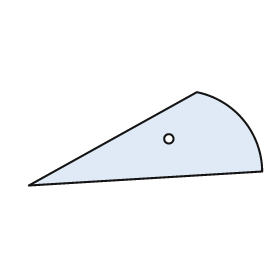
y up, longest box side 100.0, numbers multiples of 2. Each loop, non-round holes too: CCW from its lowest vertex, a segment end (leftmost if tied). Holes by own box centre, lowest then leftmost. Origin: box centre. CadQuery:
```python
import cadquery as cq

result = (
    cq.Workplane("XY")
    .moveTo(-50.0, -20.0)
    .lineTo(50.0, -14.0)
    .threePointArc((42.0, 8.0), (22.0, 20.0))
    .close()
    .moveTo(10.0, 0.0)
    .circle(2.0)
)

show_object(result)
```